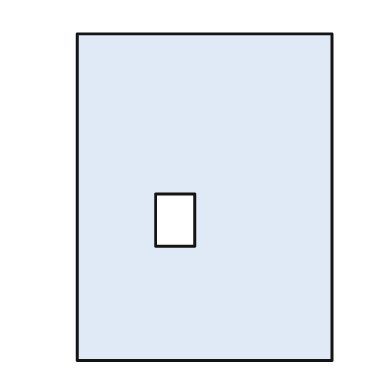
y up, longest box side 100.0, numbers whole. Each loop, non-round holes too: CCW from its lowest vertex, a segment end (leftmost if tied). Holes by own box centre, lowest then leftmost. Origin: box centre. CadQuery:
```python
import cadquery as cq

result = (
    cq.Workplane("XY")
    .moveTo(-39.0, -50.0)
    .lineTo(39.0, -50.0)
    .lineTo(39.0, 50.0)
    .lineTo(-39.0, 50.0)
    .close()
    .moveTo(-15.0, -15.0)
    .lineTo(-3.0, -15.0)
    .lineTo(-3.0, 1.0)
    .lineTo(-15.0, 1.0)
    .close()
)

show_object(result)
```